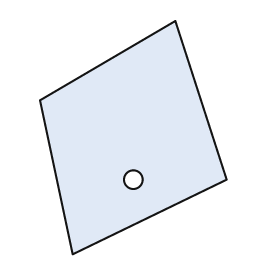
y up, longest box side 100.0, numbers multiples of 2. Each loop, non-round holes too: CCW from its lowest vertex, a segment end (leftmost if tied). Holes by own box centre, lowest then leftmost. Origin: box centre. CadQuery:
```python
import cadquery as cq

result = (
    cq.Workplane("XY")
    .moveTo(-26.0, -50.0)
    .lineTo(40.0, -18.0)
    .lineTo(18.0, 50.0)
    .lineTo(-40.0, 16.0)
    .close()
    .moveTo(0.0, -18.0)
    .circle(4.0)
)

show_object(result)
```